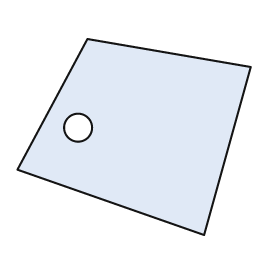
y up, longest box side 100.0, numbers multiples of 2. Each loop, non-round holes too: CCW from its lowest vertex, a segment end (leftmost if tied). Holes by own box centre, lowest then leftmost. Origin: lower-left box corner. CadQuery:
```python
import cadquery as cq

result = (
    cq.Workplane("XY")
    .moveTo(80.0, 0.0)
    .lineTo(100.0, 72.0)
    .lineTo(30.0, 84.0)
    .lineTo(0.0, 28.0)
    .close()
    .moveTo(26.0, 46.0)
    .circle(6.0)
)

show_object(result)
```